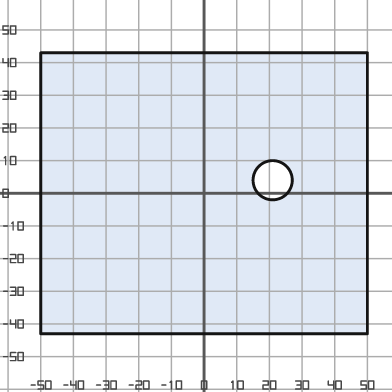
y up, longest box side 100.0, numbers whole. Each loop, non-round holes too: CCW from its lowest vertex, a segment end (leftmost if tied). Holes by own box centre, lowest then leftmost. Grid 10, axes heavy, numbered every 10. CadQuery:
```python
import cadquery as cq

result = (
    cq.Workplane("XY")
    .moveTo(-50.0, -43.0)
    .lineTo(50.0, -43.0)
    .lineTo(50.0, 43.0)
    .lineTo(-50.0, 43.0)
    .close()
    .moveTo(21.0, 4.0)
    .circle(6.0)
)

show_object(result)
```